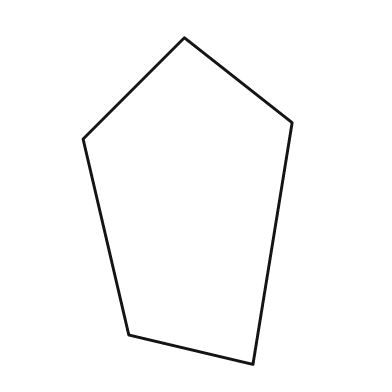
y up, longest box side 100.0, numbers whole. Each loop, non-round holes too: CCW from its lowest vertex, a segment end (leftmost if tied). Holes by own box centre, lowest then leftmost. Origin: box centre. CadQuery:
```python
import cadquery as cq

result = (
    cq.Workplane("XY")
    .moveTo(20.0, -50.0)
    .lineTo(32.0, 24.0)
    .lineTo(-1.0, 50.0)
    .lineTo(-32.0, 19.0)
    .lineTo(-18.0, -41.0)
    .close()
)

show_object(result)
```